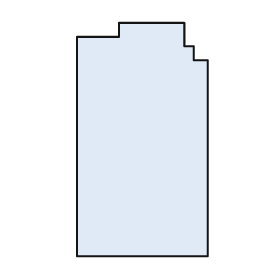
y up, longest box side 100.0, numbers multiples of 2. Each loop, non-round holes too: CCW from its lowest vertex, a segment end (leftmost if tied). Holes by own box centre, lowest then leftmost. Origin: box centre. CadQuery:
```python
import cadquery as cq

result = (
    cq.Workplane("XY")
    .moveTo(-28.0, -50.0)
    .lineTo(28.0, -50.0)
    .lineTo(28.0, 34.0)
    .lineTo(22.0, 34.0)
    .lineTo(22.0, 40.0)
    .lineTo(18.0, 40.0)
    .lineTo(18.0, 50.0)
    .lineTo(-10.0, 50.0)
    .lineTo(-10.0, 44.0)
    .lineTo(-28.0, 44.0)
    .close()
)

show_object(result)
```